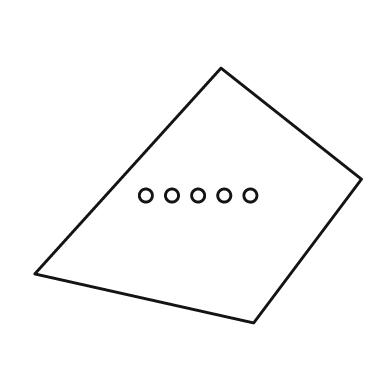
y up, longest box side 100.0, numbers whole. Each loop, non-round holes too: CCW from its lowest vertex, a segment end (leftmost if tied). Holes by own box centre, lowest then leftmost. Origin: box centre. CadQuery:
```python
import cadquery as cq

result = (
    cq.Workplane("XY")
    .moveTo(17.0, -39.0)
    .lineTo(50.0, 5.0)
    .lineTo(7.0, 39.0)
    .lineTo(-50.0, -24.0)
    .close()
    .moveTo(-16.0, 0.0)
    .circle(2.0)
    .moveTo(-8.0, 0.0)
    .circle(2.0)
    .moveTo(0.0, 0.0)
    .circle(2.0)
    .moveTo(8.0, 0.0)
    .circle(2.0)
    .moveTo(16.0, 0.0)
    .circle(2.0)
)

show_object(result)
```